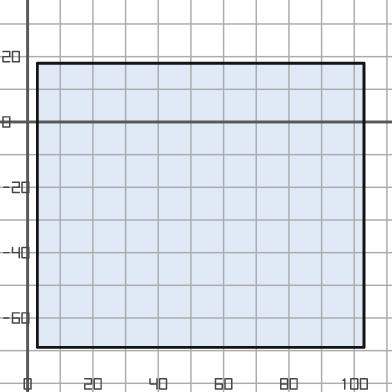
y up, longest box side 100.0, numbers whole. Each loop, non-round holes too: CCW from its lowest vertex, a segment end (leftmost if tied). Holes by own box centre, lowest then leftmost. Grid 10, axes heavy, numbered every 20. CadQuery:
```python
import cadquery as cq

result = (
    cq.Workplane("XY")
    .moveTo(3.0, -69.0)
    .lineTo(103.0, -69.0)
    .lineTo(103.0, 18.0)
    .lineTo(3.0, 18.0)
    .close()
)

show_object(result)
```